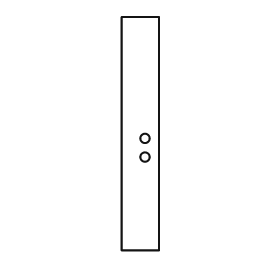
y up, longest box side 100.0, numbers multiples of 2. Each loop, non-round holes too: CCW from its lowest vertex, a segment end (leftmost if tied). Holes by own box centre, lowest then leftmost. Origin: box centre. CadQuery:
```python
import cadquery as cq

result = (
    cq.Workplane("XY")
    .moveTo(-8.0, -50.0)
    .lineTo(8.0, -50.0)
    .lineTo(8.0, 50.0)
    .lineTo(-8.0, 50.0)
    .close()
    .moveTo(2.0, -10.0)
    .circle(2.0)
    .moveTo(2.0, -2.0)
    .circle(2.0)
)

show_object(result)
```